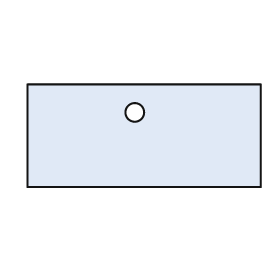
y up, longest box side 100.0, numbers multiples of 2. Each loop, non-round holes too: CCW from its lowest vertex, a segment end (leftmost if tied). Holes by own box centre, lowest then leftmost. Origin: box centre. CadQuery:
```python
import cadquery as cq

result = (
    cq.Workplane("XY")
    .moveTo(-50.0, -22.0)
    .lineTo(50.0, -22.0)
    .lineTo(50.0, 22.0)
    .lineTo(-50.0, 22.0)
    .close()
    .moveTo(-4.0, 10.0)
    .circle(4.0)
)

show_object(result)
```